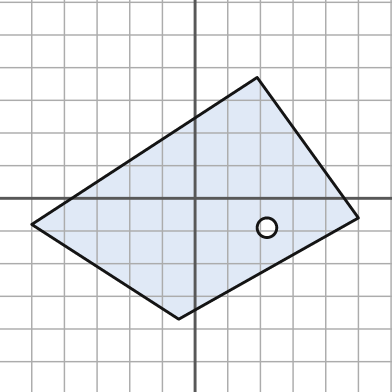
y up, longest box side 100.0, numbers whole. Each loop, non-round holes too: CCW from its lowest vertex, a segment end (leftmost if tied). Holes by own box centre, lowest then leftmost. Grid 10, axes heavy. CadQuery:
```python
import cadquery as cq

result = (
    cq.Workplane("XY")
    .moveTo(-5.0, -37.0)
    .lineTo(50.0, -6.0)
    .lineTo(19.0, 37.0)
    .lineTo(-50.0, -8.0)
    .close()
    .moveTo(22.0, -9.0)
    .circle(3.0)
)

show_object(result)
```